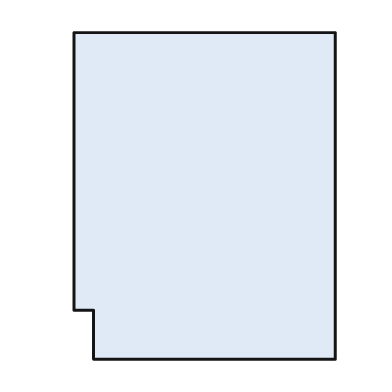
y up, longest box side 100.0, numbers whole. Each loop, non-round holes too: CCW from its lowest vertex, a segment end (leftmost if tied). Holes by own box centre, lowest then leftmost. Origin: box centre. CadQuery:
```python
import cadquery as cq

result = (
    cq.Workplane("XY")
    .moveTo(-34.0, -50.0)
    .lineTo(40.0, -50.0)
    .lineTo(40.0, 50.0)
    .lineTo(-40.0, 50.0)
    .lineTo(-40.0, -35.0)
    .lineTo(-34.0, -35.0)
    .close()
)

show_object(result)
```